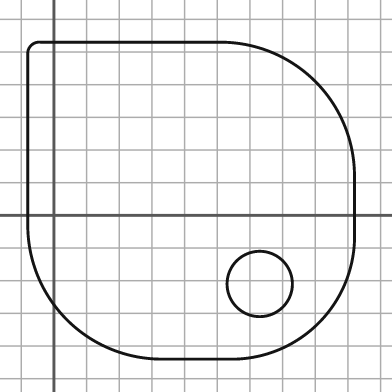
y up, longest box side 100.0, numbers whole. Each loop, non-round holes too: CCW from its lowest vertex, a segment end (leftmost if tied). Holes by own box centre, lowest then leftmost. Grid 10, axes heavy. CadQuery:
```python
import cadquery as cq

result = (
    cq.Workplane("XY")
    .moveTo(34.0, -44.0)
    .lineTo(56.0, -44.0)
    .threePointArc((81.0, -33.0), (92.0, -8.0))
    .lineTo(92.0, 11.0)
    .threePointArc((80.0, 41.0), (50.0, 53.0))
    .lineTo(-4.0, 53.0)
    .threePointArc((-7.0, 52.0), (-8.0, 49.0))
    .lineTo(-8.0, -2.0)
    .threePointArc((4.0, -32.0), (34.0, -44.0))
    .close()
    .moveTo(63.0, -21.0)
    .circle(10.0)
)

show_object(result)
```